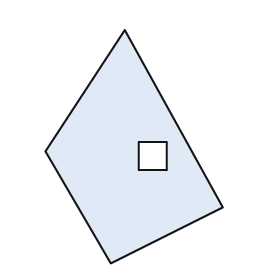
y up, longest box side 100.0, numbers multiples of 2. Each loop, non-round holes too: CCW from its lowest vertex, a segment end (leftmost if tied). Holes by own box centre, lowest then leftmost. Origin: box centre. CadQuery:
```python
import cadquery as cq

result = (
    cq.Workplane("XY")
    .moveTo(-10.0, -50.0)
    .lineTo(38.0, -26.0)
    .lineTo(-4.0, 50.0)
    .lineTo(-38.0, -2.0)
    .close()
    .moveTo(2.0, -10.0)
    .lineTo(14.0, -10.0)
    .lineTo(14.0, 2.0)
    .lineTo(2.0, 2.0)
    .close()
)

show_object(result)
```